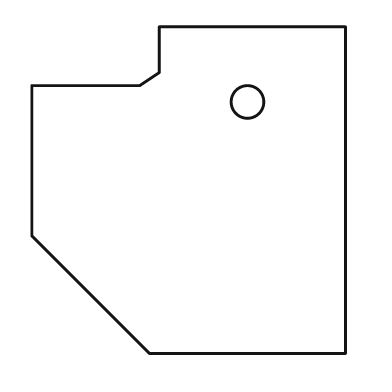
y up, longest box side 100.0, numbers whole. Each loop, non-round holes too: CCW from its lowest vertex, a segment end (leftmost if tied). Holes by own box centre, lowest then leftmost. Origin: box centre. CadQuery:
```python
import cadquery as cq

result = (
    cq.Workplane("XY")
    .moveTo(-12.0, -50.0)
    .lineTo(48.0, -50.0)
    .lineTo(48.0, 50.0)
    .lineTo(-9.0, 50.0)
    .lineTo(-9.0, 36.0)
    .lineTo(-15.0, 32.0)
    .lineTo(-48.0, 32.0)
    .lineTo(-48.0, -14.0)
    .close()
    .moveTo(18.0, 27.0)
    .circle(5.0)
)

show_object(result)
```